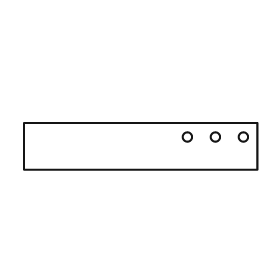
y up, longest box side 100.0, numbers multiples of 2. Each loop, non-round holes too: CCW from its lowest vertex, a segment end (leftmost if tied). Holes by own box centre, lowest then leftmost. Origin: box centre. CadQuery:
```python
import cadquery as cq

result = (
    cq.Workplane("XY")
    .moveTo(-50.0, -10.0)
    .lineTo(50.0, -10.0)
    .lineTo(50.0, 10.0)
    .lineTo(-50.0, 10.0)
    .close()
    .moveTo(20.0, 4.0)
    .circle(2.0)
    .moveTo(32.0, 4.0)
    .circle(2.0)
    .moveTo(44.0, 4.0)
    .circle(2.0)
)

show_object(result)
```